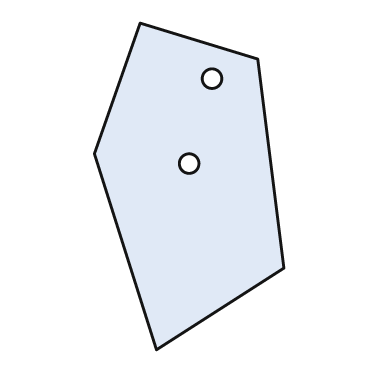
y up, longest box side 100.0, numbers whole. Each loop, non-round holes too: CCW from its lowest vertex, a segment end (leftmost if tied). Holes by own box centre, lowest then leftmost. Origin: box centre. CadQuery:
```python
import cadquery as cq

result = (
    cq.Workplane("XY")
    .moveTo(-10.0, -50.0)
    .lineTo(29.0, -25.0)
    .lineTo(21.0, 39.0)
    .lineTo(-15.0, 50.0)
    .lineTo(-29.0, 10.0)
    .close()
    .moveTo(0.0, 7.0)
    .circle(3.0)
    .moveTo(7.0, 33.0)
    .circle(3.0)
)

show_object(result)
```